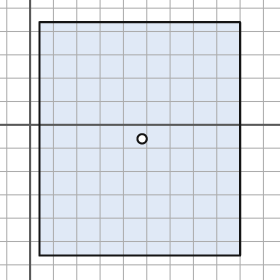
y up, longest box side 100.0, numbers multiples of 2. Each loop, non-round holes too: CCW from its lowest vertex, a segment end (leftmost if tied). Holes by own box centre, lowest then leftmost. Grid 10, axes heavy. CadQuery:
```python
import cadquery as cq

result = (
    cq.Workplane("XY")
    .moveTo(4.0, -56.0)
    .lineTo(90.0, -56.0)
    .lineTo(90.0, 44.0)
    .lineTo(4.0, 44.0)
    .close()
    .moveTo(48.0, -6.0)
    .circle(2.0)
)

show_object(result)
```